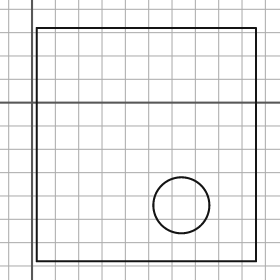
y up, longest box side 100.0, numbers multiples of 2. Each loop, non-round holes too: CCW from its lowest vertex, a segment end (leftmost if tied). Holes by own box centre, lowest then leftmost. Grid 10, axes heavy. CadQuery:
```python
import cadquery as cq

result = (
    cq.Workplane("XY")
    .moveTo(2.0, -68.0)
    .lineTo(96.0, -68.0)
    .lineTo(96.0, 32.0)
    .lineTo(2.0, 32.0)
    .close()
    .moveTo(64.0, -44.0)
    .circle(12.0)
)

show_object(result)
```